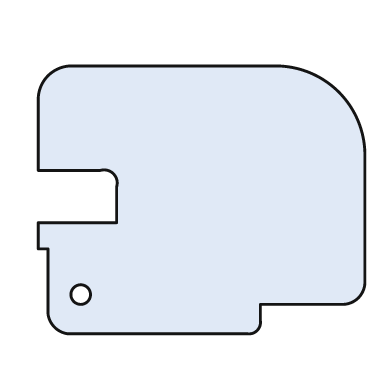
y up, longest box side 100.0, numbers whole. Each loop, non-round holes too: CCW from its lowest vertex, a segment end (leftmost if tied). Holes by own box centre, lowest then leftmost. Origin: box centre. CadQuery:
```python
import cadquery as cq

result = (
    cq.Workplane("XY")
    .moveTo(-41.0, -41.0)
    .lineTo(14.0, -41.0)
    .threePointArc((17.0, -40.0), (18.0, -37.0))
    .lineTo(18.0, -32.0)
    .lineTo(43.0, -32.0)
    .threePointArc((48.0, -30.0), (50.0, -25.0))
    .lineTo(50.0, 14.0)
    .threePointArc((42.0, 33.0), (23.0, 41.0))
    .lineTo(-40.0, 41.0)
    .threePointArc((-47.0, 38.0), (-50.0, 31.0))
    .lineTo(-50.0, 9.0)
    .lineTo(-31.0, 9.0)
    .threePointArc((-27.0, 8.0), (-26.0, 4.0))
    .lineTo(-26.0, -7.0)
    .lineTo(-50.0, -7.0)
    .lineTo(-50.0, -15.0)
    .lineTo(-47.0, -15.0)
    .lineTo(-47.0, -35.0)
    .threePointArc((-45.0, -39.0), (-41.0, -41.0))
    .close()
    .moveTo(-37.0, -29.0)
    .circle(3.0)
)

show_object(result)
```